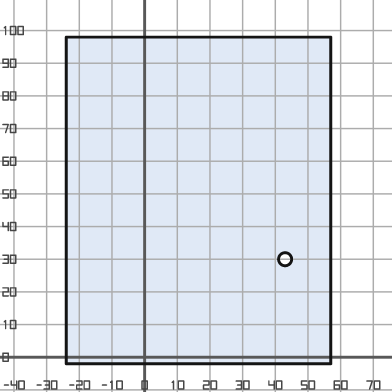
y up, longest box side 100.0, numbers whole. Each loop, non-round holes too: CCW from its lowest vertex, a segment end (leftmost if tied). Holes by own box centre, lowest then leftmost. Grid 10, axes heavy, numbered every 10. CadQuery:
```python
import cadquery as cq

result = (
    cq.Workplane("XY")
    .moveTo(-24.0, -2.0)
    .lineTo(57.0, -2.0)
    .lineTo(57.0, 98.0)
    .lineTo(-24.0, 98.0)
    .close()
    .moveTo(43.0, 30.0)
    .circle(2.0)
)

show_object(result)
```